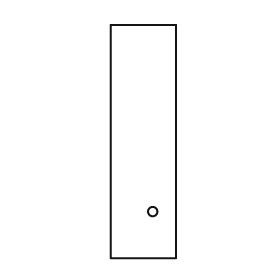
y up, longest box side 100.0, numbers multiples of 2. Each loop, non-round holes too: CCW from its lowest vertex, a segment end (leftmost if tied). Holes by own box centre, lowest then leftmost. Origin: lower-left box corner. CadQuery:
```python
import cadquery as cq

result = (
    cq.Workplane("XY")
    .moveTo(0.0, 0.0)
    .lineTo(28.0, 0.0)
    .lineTo(28.0, 100.0)
    .lineTo(0.0, 100.0)
    .close()
    .moveTo(18.0, 20.0)
    .circle(2.0)
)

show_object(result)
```